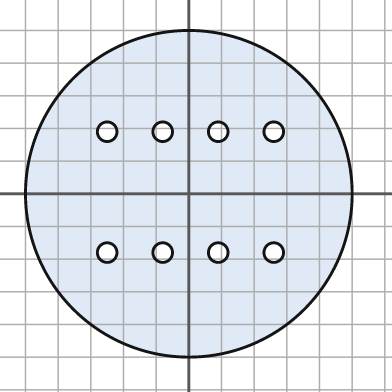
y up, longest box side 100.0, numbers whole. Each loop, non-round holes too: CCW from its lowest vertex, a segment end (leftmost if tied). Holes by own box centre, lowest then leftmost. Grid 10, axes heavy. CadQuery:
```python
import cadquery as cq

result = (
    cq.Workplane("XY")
    .moveTo(0.0, 0.0)
    .circle(50.0)
    .moveTo(-25.0, -18.0)
    .circle(3.0)
    .moveTo(-8.0, -18.0)
    .circle(3.0)
    .moveTo(9.0, -18.0)
    .circle(3.0)
    .moveTo(26.0, -18.0)
    .circle(3.0)
    .moveTo(-25.0, 19.0)
    .circle(3.0)
    .moveTo(-8.0, 19.0)
    .circle(3.0)
    .moveTo(9.0, 19.0)
    .circle(3.0)
    .moveTo(26.0, 19.0)
    .circle(3.0)
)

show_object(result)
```